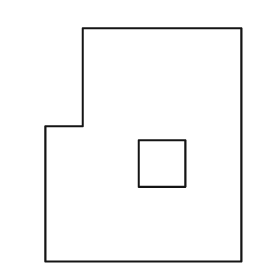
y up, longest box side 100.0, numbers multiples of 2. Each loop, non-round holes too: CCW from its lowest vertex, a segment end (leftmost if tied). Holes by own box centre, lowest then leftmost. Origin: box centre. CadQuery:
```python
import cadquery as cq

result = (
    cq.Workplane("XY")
    .moveTo(-42.0, -50.0)
    .lineTo(42.0, -50.0)
    .lineTo(42.0, 50.0)
    .lineTo(-26.0, 50.0)
    .lineTo(-26.0, 8.0)
    .lineTo(-42.0, 8.0)
    .close()
    .moveTo(-2.0, -18.0)
    .lineTo(18.0, -18.0)
    .lineTo(18.0, 2.0)
    .lineTo(-2.0, 2.0)
    .close()
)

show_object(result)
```